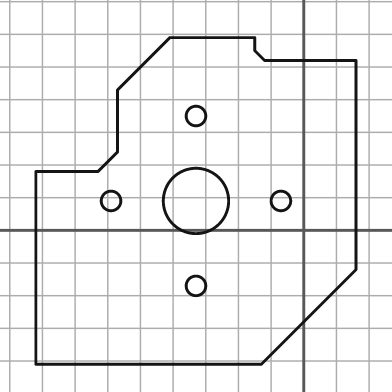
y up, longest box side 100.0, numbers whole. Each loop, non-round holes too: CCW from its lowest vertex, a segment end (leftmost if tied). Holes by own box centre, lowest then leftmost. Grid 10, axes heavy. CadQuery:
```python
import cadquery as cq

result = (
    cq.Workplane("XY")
    .moveTo(-82.0, -41.0)
    .lineTo(-13.0, -41.0)
    .lineTo(16.0, -12.0)
    .lineTo(16.0, 52.0)
    .lineTo(-12.0, 52.0)
    .lineTo(-15.0, 55.0)
    .lineTo(-15.0, 59.0)
    .lineTo(-41.0, 59.0)
    .lineTo(-57.0, 43.0)
    .lineTo(-57.0, 24.0)
    .lineTo(-63.0, 18.0)
    .lineTo(-82.0, 18.0)
    .close()
    .moveTo(-33.0, -17.0)
    .circle(3.0)
    .moveTo(-59.0, 9.0)
    .circle(3.0)
    .moveTo(-33.0, 9.0)
    .circle(10.0)
    .moveTo(-7.0, 9.0)
    .circle(3.0)
    .moveTo(-33.0, 35.0)
    .circle(3.0)
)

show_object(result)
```